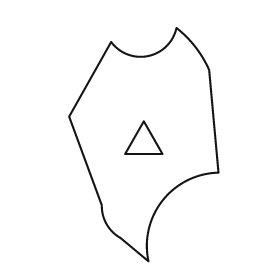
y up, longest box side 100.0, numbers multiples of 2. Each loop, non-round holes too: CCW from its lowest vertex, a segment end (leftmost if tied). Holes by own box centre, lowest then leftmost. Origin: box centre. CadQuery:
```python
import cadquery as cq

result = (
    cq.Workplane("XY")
    .moveTo(2.0, -50.0)
    .threePointArc((8.0, -24.0), (32.0, -12.0))
    .lineTo(28.0, 32.0)
    .threePointArc((22.0, 42.0), (14.0, 50.0))
    .threePointArc((2.0, 38.0), (-14.0, 44.0))
    .lineTo(-32.0, 12.0)
    .lineTo(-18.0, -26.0)
    .threePointArc((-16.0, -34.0), (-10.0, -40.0))
    .close()
    .moveTo(-8.0, -4.0)
    .lineTo(8.0, -4.0)
    .lineTo(0.0, 10.0)
    .close()
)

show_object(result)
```